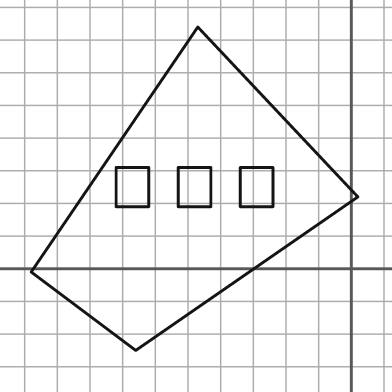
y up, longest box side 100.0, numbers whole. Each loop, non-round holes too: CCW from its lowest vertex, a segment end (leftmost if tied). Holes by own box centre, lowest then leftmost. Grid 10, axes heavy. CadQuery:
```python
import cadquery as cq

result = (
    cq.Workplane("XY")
    .moveTo(-66.0, -25.0)
    .lineTo(2.0, 22.0)
    .lineTo(-47.0, 74.0)
    .lineTo(-98.0, -1.0)
    .close()
    .moveTo(-72.0, 19.0)
    .lineTo(-62.0, 19.0)
    .lineTo(-62.0, 31.0)
    .lineTo(-72.0, 31.0)
    .close()
    .moveTo(-53.0, 19.0)
    .lineTo(-43.0, 19.0)
    .lineTo(-43.0, 31.0)
    .lineTo(-53.0, 31.0)
    .close()
    .moveTo(-34.0, 19.0)
    .lineTo(-24.0, 19.0)
    .lineTo(-24.0, 31.0)
    .lineTo(-34.0, 31.0)
    .close()
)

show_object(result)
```